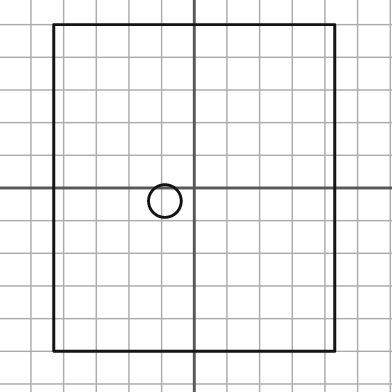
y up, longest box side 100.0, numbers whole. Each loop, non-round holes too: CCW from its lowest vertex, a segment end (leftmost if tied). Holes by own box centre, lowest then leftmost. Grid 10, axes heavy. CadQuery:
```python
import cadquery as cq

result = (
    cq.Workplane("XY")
    .moveTo(-43.0, -50.0)
    .lineTo(43.0, -50.0)
    .lineTo(43.0, 50.0)
    .lineTo(-43.0, 50.0)
    .close()
    .moveTo(-9.0, -4.0)
    .circle(5.0)
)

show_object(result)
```